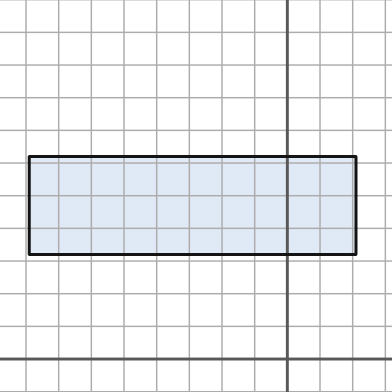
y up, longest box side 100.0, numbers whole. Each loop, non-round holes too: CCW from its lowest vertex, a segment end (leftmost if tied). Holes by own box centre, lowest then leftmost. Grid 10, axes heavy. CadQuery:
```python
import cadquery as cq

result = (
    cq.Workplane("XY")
    .moveTo(-79.0, 32.0)
    .lineTo(21.0, 32.0)
    .lineTo(21.0, 62.0)
    .lineTo(-79.0, 62.0)
    .close()
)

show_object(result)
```